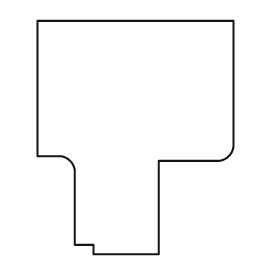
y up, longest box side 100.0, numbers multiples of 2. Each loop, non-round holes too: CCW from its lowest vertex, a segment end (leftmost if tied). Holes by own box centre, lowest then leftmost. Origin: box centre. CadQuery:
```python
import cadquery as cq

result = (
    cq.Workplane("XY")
    .moveTo(-18.0, -50.0)
    .lineTo(10.0, -50.0)
    .lineTo(10.0, -10.0)
    .lineTo(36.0, -10.0)
    .threePointArc((40.0, -8.0), (42.0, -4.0))
    .lineTo(42.0, 50.0)
    .lineTo(-42.0, 50.0)
    .lineTo(-42.0, -8.0)
    .lineTo(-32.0, -8.0)
    .threePointArc((-28.0, -10.0), (-26.0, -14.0))
    .lineTo(-26.0, -46.0)
    .lineTo(-18.0, -46.0)
    .close()
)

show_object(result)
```